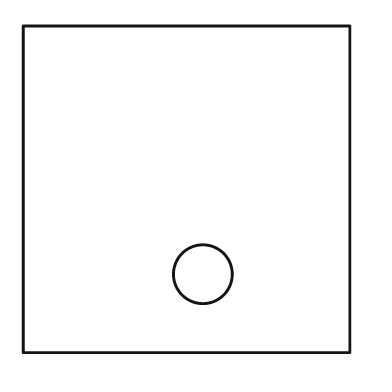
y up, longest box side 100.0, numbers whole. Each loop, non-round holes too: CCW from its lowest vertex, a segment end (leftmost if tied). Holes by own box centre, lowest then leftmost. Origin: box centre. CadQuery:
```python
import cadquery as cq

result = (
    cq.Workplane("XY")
    .moveTo(-50.0, -50.0)
    .lineTo(50.0, -50.0)
    .lineTo(50.0, 50.0)
    .lineTo(-50.0, 50.0)
    .close()
    .moveTo(5.0, -26.0)
    .circle(9.0)
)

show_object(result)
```